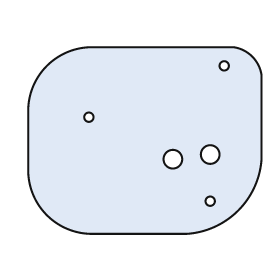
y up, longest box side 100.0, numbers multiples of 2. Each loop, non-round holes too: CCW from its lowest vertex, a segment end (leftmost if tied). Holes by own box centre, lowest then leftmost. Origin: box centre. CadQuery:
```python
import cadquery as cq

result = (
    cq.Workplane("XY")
    .moveTo(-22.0, -40.0)
    .lineTo(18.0, -40.0)
    .threePointArc((40.0, -30.0), (50.0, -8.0))
    .lineTo(50.0, 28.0)
    .threePointArc((46.0, 36.0), (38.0, 40.0))
    .lineTo(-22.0, 40.0)
    .threePointArc((-42.0, 32.0), (-50.0, 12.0))
    .lineTo(-50.0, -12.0)
    .threePointArc((-42.0, -32.0), (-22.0, -40.0))
    .close()
    .moveTo(28.0, -26.0)
    .circle(2.0)
    .moveTo(12.0, -8.0)
    .circle(4.0)
    .moveTo(28.0, -6.0)
    .circle(4.0)
    .moveTo(-24.0, 10.0)
    .circle(2.0)
    .moveTo(34.0, 32.0)
    .circle(2.0)
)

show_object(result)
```